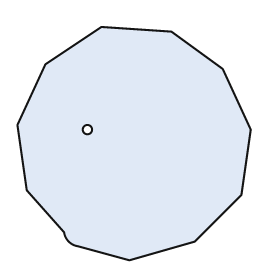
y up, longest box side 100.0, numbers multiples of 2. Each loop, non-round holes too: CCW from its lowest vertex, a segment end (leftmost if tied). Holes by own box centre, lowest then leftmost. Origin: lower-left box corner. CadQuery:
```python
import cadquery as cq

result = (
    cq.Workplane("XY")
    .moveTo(48.0, 0.0)
    .lineTo(76.0, 8.0)
    .lineTo(96.0, 28.0)
    .lineTo(100.0, 56.0)
    .lineTo(88.0, 82.0)
    .lineTo(66.0, 98.0)
    .lineTo(36.0, 100.0)
    .lineTo(12.0, 84.0)
    .lineTo(0.0, 58.0)
    .lineTo(4.0, 30.0)
    .lineTo(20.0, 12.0)
    .threePointArc((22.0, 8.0), (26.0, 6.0))
    .close()
    .moveTo(30.0, 56.0)
    .circle(2.0)
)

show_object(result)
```